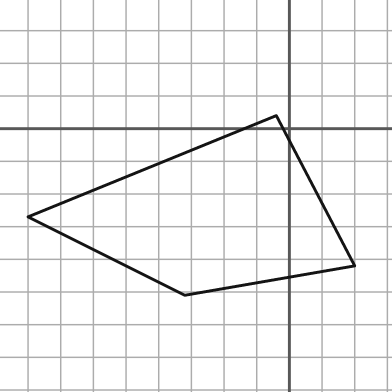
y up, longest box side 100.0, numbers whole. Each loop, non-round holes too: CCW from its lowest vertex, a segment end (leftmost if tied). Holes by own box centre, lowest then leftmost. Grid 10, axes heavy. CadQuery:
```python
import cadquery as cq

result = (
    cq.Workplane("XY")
    .moveTo(-32.0, -51.0)
    .lineTo(20.0, -42.0)
    .lineTo(-4.0, 4.0)
    .lineTo(-80.0, -27.0)
    .close()
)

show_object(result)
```